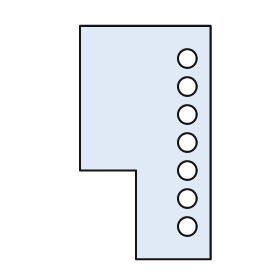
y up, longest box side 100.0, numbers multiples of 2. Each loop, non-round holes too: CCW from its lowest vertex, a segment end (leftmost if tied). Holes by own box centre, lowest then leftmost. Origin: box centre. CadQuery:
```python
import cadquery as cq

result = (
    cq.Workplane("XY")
    .moveTo(-4.0, -50.0)
    .lineTo(28.0, -50.0)
    .lineTo(28.0, 50.0)
    .lineTo(-28.0, 50.0)
    .lineTo(-28.0, -12.0)
    .lineTo(-4.0, -12.0)
    .close()
    .moveTo(18.0, -36.0)
    .circle(4.0)
    .moveTo(18.0, -24.0)
    .circle(4.0)
    .moveTo(18.0, -12.0)
    .circle(4.0)
    .moveTo(18.0, 0.0)
    .circle(4.0)
    .moveTo(18.0, 12.0)
    .circle(4.0)
    .moveTo(18.0, 24.0)
    .circle(4.0)
    .moveTo(18.0, 36.0)
    .circle(4.0)
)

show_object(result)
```